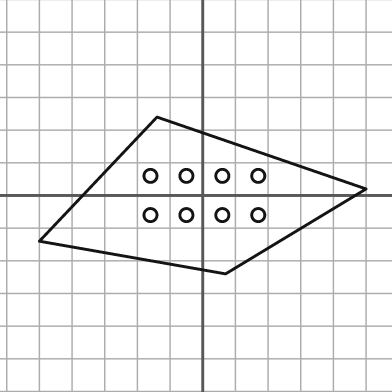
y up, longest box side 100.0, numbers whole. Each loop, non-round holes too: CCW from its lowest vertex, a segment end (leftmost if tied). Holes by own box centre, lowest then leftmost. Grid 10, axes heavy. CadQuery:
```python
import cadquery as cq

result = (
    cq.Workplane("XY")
    .moveTo(7.0, -24.0)
    .lineTo(50.0, 2.0)
    .lineTo(-14.0, 24.0)
    .lineTo(-50.0, -14.0)
    .close()
    .moveTo(-16.0, -6.0)
    .circle(2.0)
    .moveTo(-5.0, -6.0)
    .circle(2.0)
    .moveTo(6.0, -6.0)
    .circle(2.0)
    .moveTo(17.0, -6.0)
    .circle(2.0)
    .moveTo(-16.0, 6.0)
    .circle(2.0)
    .moveTo(-5.0, 6.0)
    .circle(2.0)
    .moveTo(6.0, 6.0)
    .circle(2.0)
    .moveTo(17.0, 6.0)
    .circle(2.0)
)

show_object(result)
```